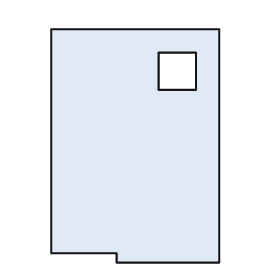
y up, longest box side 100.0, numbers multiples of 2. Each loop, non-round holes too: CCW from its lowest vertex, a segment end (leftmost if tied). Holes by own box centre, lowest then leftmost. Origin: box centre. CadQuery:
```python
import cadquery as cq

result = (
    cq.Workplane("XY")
    .moveTo(-8.0, -50.0)
    .lineTo(36.0, -50.0)
    .lineTo(36.0, 50.0)
    .lineTo(-36.0, 50.0)
    .lineTo(-36.0, -46.0)
    .lineTo(-8.0, -46.0)
    .close()
    .moveTo(10.0, 24.0)
    .lineTo(26.0, 24.0)
    .lineTo(26.0, 40.0)
    .lineTo(10.0, 40.0)
    .close()
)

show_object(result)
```